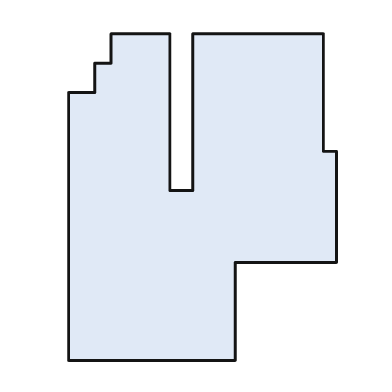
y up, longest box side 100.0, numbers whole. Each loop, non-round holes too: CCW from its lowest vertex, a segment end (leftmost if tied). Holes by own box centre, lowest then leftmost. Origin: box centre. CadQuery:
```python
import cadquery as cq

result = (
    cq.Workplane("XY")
    .moveTo(-41.0, -50.0)
    .lineTo(10.0, -50.0)
    .lineTo(10.0, -20.0)
    .lineTo(41.0, -20.0)
    .lineTo(41.0, 14.0)
    .lineTo(37.0, 14.0)
    .lineTo(37.0, 50.0)
    .lineTo(-3.0, 50.0)
    .lineTo(-3.0, 2.0)
    .lineTo(-10.0, 2.0)
    .lineTo(-10.0, 50.0)
    .lineTo(-28.0, 50.0)
    .lineTo(-28.0, 41.0)
    .lineTo(-33.0, 41.0)
    .lineTo(-33.0, 32.0)
    .lineTo(-41.0, 32.0)
    .close()
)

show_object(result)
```